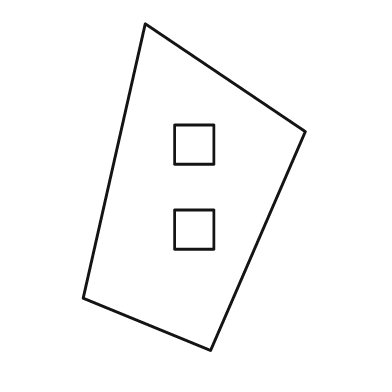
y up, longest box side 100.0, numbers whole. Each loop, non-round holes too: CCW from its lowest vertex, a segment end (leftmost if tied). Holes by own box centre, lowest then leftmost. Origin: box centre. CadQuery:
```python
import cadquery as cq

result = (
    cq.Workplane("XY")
    .moveTo(5.0, -50.0)
    .lineTo(34.0, 17.0)
    .lineTo(-15.0, 50.0)
    .lineTo(-34.0, -34.0)
    .close()
    .moveTo(-6.0, -19.0)
    .lineTo(6.0, -19.0)
    .lineTo(6.0, -7.0)
    .lineTo(-6.0, -7.0)
    .close()
    .moveTo(-6.0, 7.0)
    .lineTo(6.0, 7.0)
    .lineTo(6.0, 19.0)
    .lineTo(-6.0, 19.0)
    .close()
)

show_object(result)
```